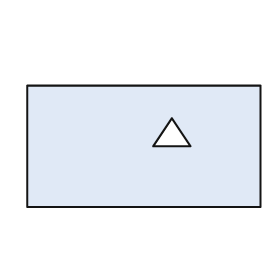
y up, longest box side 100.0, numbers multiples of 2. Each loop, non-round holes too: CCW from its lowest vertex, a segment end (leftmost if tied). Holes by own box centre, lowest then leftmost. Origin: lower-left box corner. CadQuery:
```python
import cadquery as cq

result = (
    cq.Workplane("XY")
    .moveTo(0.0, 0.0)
    .lineTo(100.0, 0.0)
    .lineTo(100.0, 52.0)
    .lineTo(0.0, 52.0)
    .close()
    .moveTo(54.0, 26.0)
    .lineTo(70.0, 26.0)
    .lineTo(62.0, 38.0)
    .close()
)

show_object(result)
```